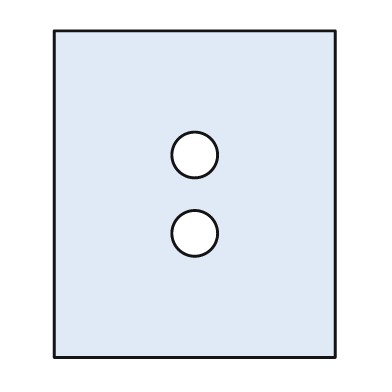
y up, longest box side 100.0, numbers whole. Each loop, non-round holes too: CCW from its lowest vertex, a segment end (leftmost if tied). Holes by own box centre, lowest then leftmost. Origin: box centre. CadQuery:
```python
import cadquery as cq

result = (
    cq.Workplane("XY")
    .moveTo(-43.0, -50.0)
    .lineTo(43.0, -50.0)
    .lineTo(43.0, 50.0)
    .lineTo(-43.0, 50.0)
    .close()
    .moveTo(0.0, -12.0)
    .circle(7.0)
    .moveTo(0.0, 12.0)
    .circle(7.0)
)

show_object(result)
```